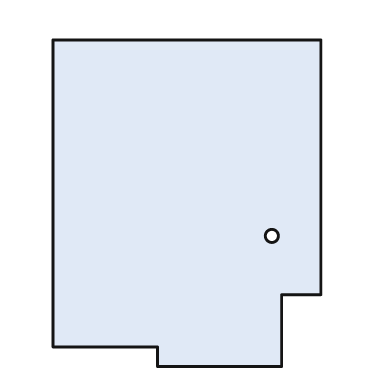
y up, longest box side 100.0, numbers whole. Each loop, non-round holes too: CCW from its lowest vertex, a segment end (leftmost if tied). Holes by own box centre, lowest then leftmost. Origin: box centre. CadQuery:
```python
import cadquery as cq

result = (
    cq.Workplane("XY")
    .moveTo(-9.0, -50.0)
    .lineTo(29.0, -50.0)
    .lineTo(29.0, -28.0)
    .lineTo(41.0, -28.0)
    .lineTo(41.0, 50.0)
    .lineTo(-41.0, 50.0)
    .lineTo(-41.0, -44.0)
    .lineTo(-9.0, -44.0)
    .close()
    .moveTo(26.0, -10.0)
    .circle(2.0)
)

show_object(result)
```